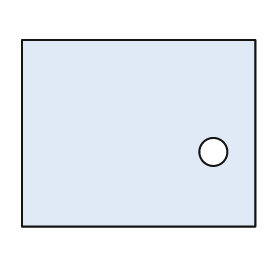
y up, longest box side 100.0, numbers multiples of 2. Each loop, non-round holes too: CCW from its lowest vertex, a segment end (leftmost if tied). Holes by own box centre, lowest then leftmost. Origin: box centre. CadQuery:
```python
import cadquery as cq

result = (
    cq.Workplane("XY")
    .moveTo(-50.0, -40.0)
    .lineTo(50.0, -40.0)
    .lineTo(50.0, 40.0)
    .lineTo(-50.0, 40.0)
    .close()
    .moveTo(32.0, -8.0)
    .circle(6.0)
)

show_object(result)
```